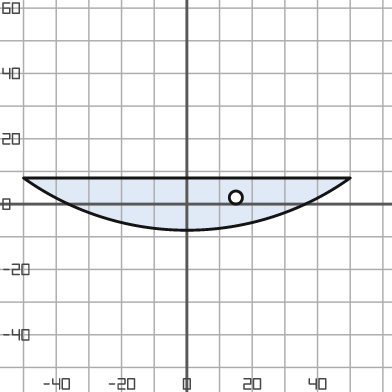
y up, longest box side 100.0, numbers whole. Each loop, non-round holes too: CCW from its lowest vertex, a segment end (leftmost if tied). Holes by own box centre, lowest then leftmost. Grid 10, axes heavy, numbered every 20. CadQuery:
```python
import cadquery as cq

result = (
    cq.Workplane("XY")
    .moveTo(-50.0, 8.0)
    .threePointArc((0.0, -8.0), (50.0, 8.0))
    .close()
    .moveTo(15.0, 2.0)
    .circle(2.0)
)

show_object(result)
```